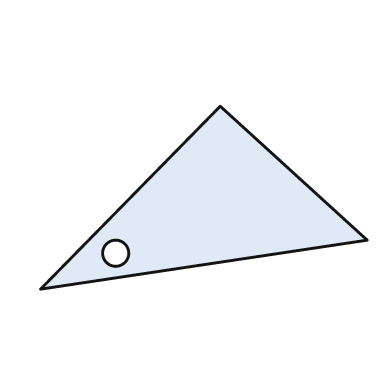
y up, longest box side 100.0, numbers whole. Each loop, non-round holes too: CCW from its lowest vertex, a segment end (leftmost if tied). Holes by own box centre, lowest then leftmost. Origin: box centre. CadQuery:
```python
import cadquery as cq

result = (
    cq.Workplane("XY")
    .moveTo(-50.0, -28.0)
    .lineTo(50.0, -13.0)
    .lineTo(5.0, 28.0)
    .close()
    .moveTo(-27.0, -17.0)
    .circle(4.0)
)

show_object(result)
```